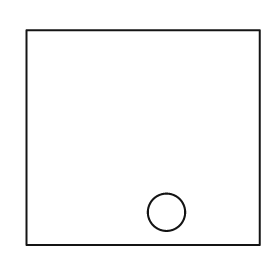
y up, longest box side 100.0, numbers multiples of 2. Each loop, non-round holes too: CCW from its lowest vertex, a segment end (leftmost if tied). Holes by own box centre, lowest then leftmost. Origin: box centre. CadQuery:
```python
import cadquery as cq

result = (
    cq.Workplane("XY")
    .moveTo(-50.0, -46.0)
    .lineTo(50.0, -46.0)
    .lineTo(50.0, 46.0)
    .lineTo(-50.0, 46.0)
    .close()
    .moveTo(10.0, -32.0)
    .circle(8.0)
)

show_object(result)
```